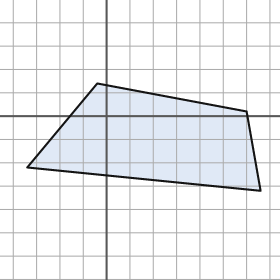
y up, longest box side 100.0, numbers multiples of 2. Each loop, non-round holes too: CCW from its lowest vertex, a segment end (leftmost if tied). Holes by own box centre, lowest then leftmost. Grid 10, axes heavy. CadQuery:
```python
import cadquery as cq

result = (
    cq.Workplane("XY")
    .moveTo(66.0, -32.0)
    .lineTo(60.0, 2.0)
    .lineTo(-4.0, 14.0)
    .lineTo(-34.0, -22.0)
    .close()
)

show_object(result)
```